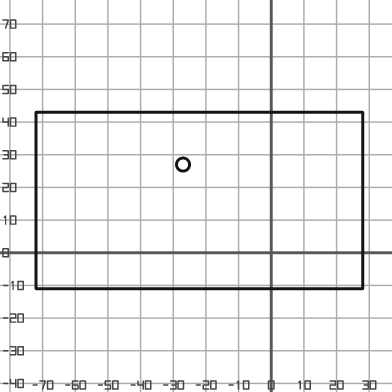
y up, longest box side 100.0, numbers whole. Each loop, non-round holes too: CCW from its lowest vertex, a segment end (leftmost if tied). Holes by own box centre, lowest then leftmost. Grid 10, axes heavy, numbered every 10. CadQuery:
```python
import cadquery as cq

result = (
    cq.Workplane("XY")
    .moveTo(-72.0, -11.0)
    .lineTo(28.0, -11.0)
    .lineTo(28.0, 43.0)
    .lineTo(-72.0, 43.0)
    .close()
    .moveTo(-27.0, 27.0)
    .circle(2.0)
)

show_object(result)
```